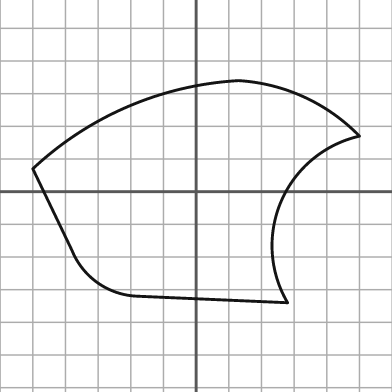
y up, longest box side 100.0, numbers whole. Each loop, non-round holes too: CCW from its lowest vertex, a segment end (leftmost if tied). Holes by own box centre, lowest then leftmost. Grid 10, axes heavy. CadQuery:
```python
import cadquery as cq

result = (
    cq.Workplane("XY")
    .moveTo(28.0, -34.0)
    .threePointArc((26.0, -3.0), (50.0, 17.0))
    .threePointArc((33.0, 29.0), (13.0, 34.0))
    .threePointArc((-21.0, 26.0), (-50.0, 7.0))
    .lineTo(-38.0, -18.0)
    .threePointArc((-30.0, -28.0), (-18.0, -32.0))
    .close()
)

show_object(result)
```